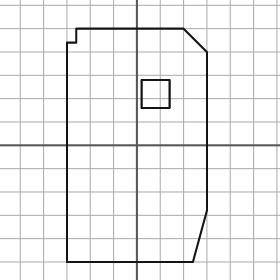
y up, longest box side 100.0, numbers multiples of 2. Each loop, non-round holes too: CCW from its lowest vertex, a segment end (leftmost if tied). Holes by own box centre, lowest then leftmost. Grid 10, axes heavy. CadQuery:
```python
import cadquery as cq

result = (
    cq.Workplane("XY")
    .moveTo(-30.0, -50.0)
    .lineTo(24.0, -50.0)
    .lineTo(30.0, -28.0)
    .lineTo(30.0, 40.0)
    .lineTo(20.0, 50.0)
    .lineTo(-26.0, 50.0)
    .lineTo(-26.0, 44.0)
    .lineTo(-30.0, 44.0)
    .close()
    .moveTo(2.0, 16.0)
    .lineTo(14.0, 16.0)
    .lineTo(14.0, 28.0)
    .lineTo(2.0, 28.0)
    .close()
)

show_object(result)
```